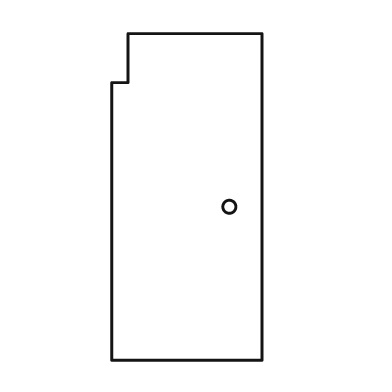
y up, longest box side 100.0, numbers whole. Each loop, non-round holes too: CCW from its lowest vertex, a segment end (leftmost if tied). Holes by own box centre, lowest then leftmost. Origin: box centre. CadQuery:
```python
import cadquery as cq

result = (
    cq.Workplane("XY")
    .moveTo(-23.0, -50.0)
    .lineTo(23.0, -50.0)
    .lineTo(23.0, 50.0)
    .lineTo(-18.0, 50.0)
    .lineTo(-18.0, 35.0)
    .lineTo(-23.0, 35.0)
    .close()
    .moveTo(13.0, -3.0)
    .circle(2.0)
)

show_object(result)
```